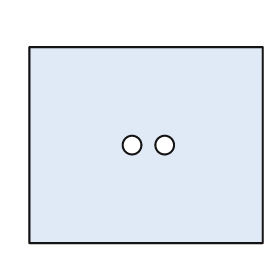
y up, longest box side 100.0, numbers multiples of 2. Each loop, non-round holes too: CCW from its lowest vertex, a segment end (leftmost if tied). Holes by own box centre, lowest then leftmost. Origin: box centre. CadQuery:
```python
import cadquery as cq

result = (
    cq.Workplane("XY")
    .moveTo(-50.0, -42.0)
    .lineTo(50.0, -42.0)
    .lineTo(50.0, 42.0)
    .lineTo(-50.0, 42.0)
    .close()
    .moveTo(-6.0, 0.0)
    .circle(4.0)
    .moveTo(8.0, 0.0)
    .circle(4.0)
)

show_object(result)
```